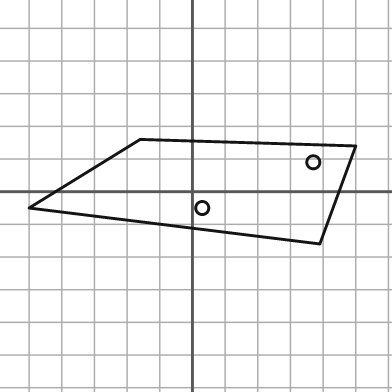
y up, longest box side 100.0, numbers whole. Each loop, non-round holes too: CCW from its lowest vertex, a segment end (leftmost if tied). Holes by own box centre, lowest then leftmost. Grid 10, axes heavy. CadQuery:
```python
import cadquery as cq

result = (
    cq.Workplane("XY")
    .moveTo(39.0, -16.0)
    .lineTo(50.0, 14.0)
    .lineTo(-16.0, 16.0)
    .lineTo(-50.0, -5.0)
    .close()
    .moveTo(3.0, -5.0)
    .circle(2.0)
    .moveTo(37.0, 9.0)
    .circle(2.0)
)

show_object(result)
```